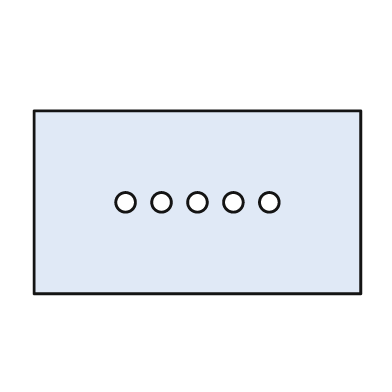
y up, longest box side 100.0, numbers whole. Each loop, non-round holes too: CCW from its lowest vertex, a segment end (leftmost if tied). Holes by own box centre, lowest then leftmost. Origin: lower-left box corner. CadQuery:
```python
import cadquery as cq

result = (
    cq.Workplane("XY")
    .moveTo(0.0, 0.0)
    .lineTo(100.0, 0.0)
    .lineTo(100.0, 56.0)
    .lineTo(0.0, 56.0)
    .close()
    .moveTo(28.0, 28.0)
    .circle(3.0)
    .moveTo(39.0, 28.0)
    .circle(3.0)
    .moveTo(50.0, 28.0)
    .circle(3.0)
    .moveTo(61.0, 28.0)
    .circle(3.0)
    .moveTo(72.0, 28.0)
    .circle(3.0)
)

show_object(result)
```